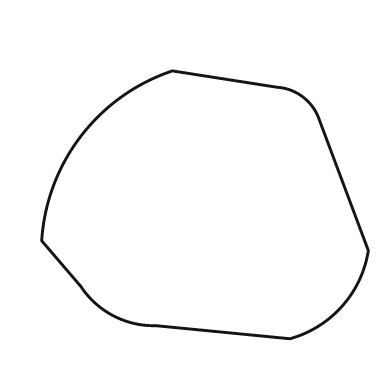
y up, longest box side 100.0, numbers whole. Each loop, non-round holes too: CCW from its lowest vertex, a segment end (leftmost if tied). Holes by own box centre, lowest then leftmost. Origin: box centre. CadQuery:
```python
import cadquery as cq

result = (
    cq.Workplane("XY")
    .moveTo(26.0, -41.0)
    .threePointArc((42.0, -31.0), (50.0, -14.0))
    .lineTo(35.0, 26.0)
    .threePointArc((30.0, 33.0), (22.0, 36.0))
    .lineTo(-10.0, 41.0)
    .threePointArc((-38.0, 21.0), (-50.0, -11.0))
    .lineTo(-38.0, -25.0)
    .threePointArc((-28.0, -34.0), (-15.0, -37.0))
    .close()
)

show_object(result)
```